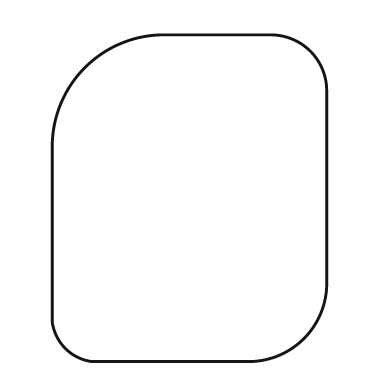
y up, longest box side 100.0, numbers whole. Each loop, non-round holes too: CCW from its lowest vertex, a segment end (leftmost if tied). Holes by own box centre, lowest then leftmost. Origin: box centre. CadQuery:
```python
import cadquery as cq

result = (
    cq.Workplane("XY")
    .moveTo(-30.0, -50.0)
    .lineTo(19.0, -50.0)
    .threePointArc((35.0, -43.0), (42.0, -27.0))
    .lineTo(42.0, 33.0)
    .threePointArc((37.0, 45.0), (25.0, 50.0))
    .lineTo(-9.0, 50.0)
    .threePointArc((-32.0, 40.0), (-42.0, 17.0))
    .lineTo(-42.0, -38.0)
    .threePointArc((-38.0, -46.0), (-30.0, -50.0))
    .close()
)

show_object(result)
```